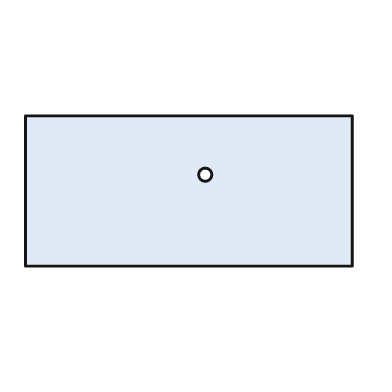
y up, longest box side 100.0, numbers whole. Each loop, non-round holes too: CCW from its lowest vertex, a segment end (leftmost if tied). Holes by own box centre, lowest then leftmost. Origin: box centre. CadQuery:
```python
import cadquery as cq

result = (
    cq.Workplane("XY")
    .moveTo(-50.0, -23.0)
    .lineTo(50.0, -23.0)
    .lineTo(50.0, 23.0)
    .lineTo(-50.0, 23.0)
    .close()
    .moveTo(5.0, 5.0)
    .circle(2.0)
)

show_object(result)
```